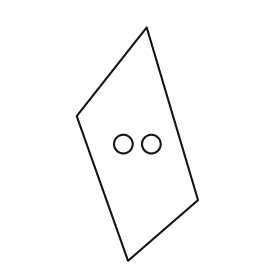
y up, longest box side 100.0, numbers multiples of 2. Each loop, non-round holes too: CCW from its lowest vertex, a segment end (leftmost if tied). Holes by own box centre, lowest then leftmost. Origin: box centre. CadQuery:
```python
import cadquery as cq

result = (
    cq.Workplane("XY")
    .moveTo(-4.0, -50.0)
    .lineTo(26.0, -24.0)
    .lineTo(4.0, 50.0)
    .lineTo(-26.0, 12.0)
    .close()
    .moveTo(-6.0, 0.0)
    .circle(4.0)
    .moveTo(6.0, 0.0)
    .circle(4.0)
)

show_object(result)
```